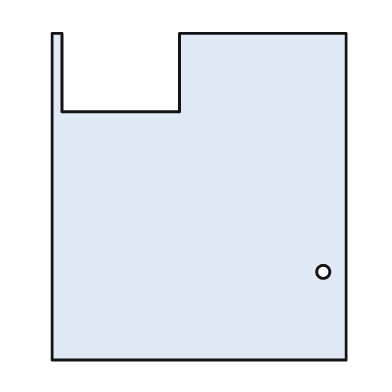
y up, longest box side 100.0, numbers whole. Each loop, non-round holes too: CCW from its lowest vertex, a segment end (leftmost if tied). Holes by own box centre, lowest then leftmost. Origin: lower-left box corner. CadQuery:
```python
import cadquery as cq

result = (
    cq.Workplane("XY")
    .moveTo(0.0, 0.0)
    .lineTo(90.0, 0.0)
    .lineTo(90.0, 100.0)
    .lineTo(39.0, 100.0)
    .lineTo(39.0, 76.0)
    .lineTo(3.0, 76.0)
    .lineTo(3.0, 100.0)
    .lineTo(0.0, 100.0)
    .close()
    .moveTo(83.0, 27.0)
    .circle(2.0)
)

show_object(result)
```